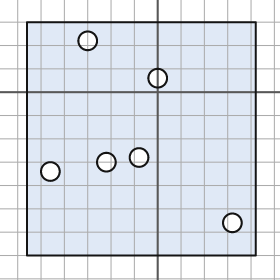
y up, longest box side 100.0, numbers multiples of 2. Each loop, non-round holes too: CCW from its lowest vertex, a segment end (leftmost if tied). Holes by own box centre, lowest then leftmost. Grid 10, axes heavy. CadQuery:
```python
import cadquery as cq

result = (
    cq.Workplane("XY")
    .moveTo(-56.0, -70.0)
    .lineTo(42.0, -70.0)
    .lineTo(42.0, 30.0)
    .lineTo(-56.0, 30.0)
    .close()
    .moveTo(32.0, -56.0)
    .circle(4.0)
    .moveTo(-46.0, -34.0)
    .circle(4.0)
    .moveTo(-22.0, -30.0)
    .circle(4.0)
    .moveTo(-8.0, -28.0)
    .circle(4.0)
    .moveTo(0.0, 6.0)
    .circle(4.0)
    .moveTo(-30.0, 22.0)
    .circle(4.0)
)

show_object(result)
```